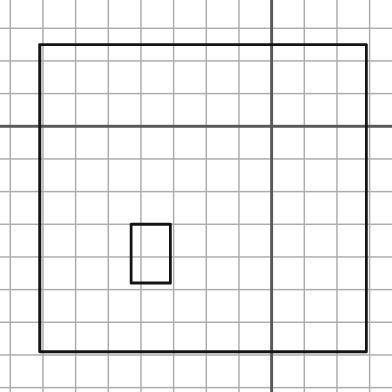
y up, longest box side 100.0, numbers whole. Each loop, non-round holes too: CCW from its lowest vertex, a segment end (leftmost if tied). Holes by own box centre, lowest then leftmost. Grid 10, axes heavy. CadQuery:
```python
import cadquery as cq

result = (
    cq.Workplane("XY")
    .moveTo(-71.0, -69.0)
    .lineTo(29.0, -69.0)
    .lineTo(29.0, 25.0)
    .lineTo(-71.0, 25.0)
    .close()
    .moveTo(-43.0, -48.0)
    .lineTo(-31.0, -48.0)
    .lineTo(-31.0, -30.0)
    .lineTo(-43.0, -30.0)
    .close()
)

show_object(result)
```